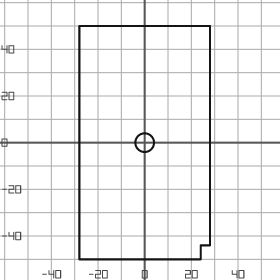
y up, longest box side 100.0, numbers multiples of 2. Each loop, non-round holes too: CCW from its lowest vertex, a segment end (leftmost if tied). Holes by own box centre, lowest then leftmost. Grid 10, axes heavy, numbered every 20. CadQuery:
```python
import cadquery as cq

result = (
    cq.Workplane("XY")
    .moveTo(-28.0, -50.0)
    .lineTo(24.0, -50.0)
    .lineTo(24.0, -44.0)
    .lineTo(28.0, -44.0)
    .lineTo(28.0, 50.0)
    .lineTo(-28.0, 50.0)
    .close()
    .moveTo(0.0, 0.0)
    .circle(4.0)
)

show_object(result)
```